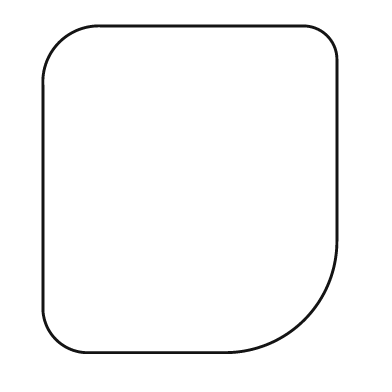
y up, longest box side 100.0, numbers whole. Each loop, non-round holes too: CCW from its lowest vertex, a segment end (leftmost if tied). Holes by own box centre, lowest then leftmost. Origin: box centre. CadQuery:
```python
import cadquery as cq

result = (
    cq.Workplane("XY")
    .moveTo(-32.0, -50.0)
    .lineTo(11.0, -50.0)
    .threePointArc((35.0, -40.0), (45.0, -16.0))
    .lineTo(45.0, 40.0)
    .threePointArc((42.0, 47.0), (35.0, 50.0))
    .lineTo(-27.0, 50.0)
    .threePointArc((-40.0, 45.0), (-45.0, 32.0))
    .lineTo(-45.0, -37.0)
    .threePointArc((-41.0, -46.0), (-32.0, -50.0))
    .close()
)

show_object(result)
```